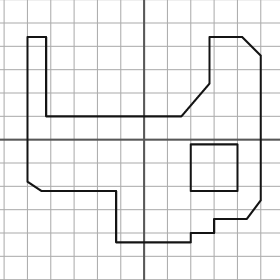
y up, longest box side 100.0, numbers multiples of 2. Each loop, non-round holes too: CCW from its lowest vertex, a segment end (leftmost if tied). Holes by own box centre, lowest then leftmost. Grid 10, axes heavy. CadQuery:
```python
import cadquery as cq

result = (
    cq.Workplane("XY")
    .moveTo(-12.0, -44.0)
    .lineTo(20.0, -44.0)
    .lineTo(20.0, -40.0)
    .lineTo(30.0, -40.0)
    .lineTo(30.0, -34.0)
    .lineTo(44.0, -34.0)
    .lineTo(50.0, -26.0)
    .lineTo(50.0, 36.0)
    .lineTo(42.0, 44.0)
    .lineTo(28.0, 44.0)
    .lineTo(28.0, 24.0)
    .lineTo(16.0, 10.0)
    .lineTo(-42.0, 10.0)
    .lineTo(-42.0, 44.0)
    .lineTo(-50.0, 44.0)
    .lineTo(-50.0, -18.0)
    .lineTo(-44.0, -22.0)
    .lineTo(-12.0, -22.0)
    .close()
    .moveTo(20.0, -22.0)
    .lineTo(40.0, -22.0)
    .lineTo(40.0, -2.0)
    .lineTo(20.0, -2.0)
    .close()
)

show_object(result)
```